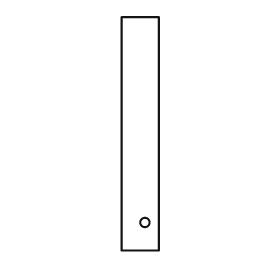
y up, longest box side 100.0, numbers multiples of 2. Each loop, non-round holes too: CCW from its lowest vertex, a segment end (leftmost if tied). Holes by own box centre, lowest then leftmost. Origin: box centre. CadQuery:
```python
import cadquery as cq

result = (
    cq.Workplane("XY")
    .moveTo(-8.0, -50.0)
    .lineTo(8.0, -50.0)
    .lineTo(8.0, 50.0)
    .lineTo(-8.0, 50.0)
    .close()
    .moveTo(2.0, -38.0)
    .circle(2.0)
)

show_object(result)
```